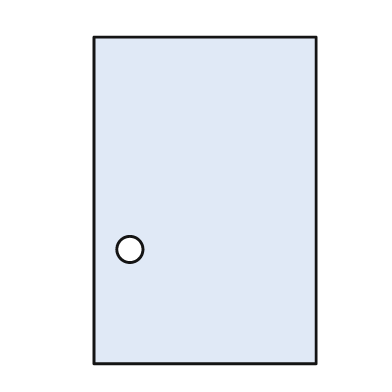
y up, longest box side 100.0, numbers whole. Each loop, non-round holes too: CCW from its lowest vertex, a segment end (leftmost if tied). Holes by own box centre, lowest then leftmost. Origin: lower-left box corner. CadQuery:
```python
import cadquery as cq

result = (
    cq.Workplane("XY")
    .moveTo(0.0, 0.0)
    .lineTo(68.0, 0.0)
    .lineTo(68.0, 100.0)
    .lineTo(0.0, 100.0)
    .close()
    .moveTo(11.0, 35.0)
    .circle(4.0)
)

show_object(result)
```